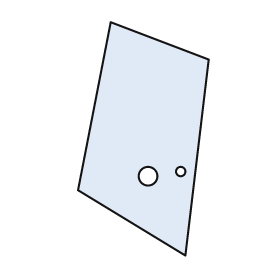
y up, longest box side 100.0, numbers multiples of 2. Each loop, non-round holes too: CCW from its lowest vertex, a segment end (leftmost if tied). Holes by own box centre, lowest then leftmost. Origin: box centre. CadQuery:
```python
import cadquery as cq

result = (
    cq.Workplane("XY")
    .moveTo(18.0, -50.0)
    .lineTo(28.0, 34.0)
    .lineTo(-14.0, 50.0)
    .lineTo(-28.0, -22.0)
    .close()
    .moveTo(2.0, -16.0)
    .circle(4.0)
    .moveTo(16.0, -14.0)
    .circle(2.0)
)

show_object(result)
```